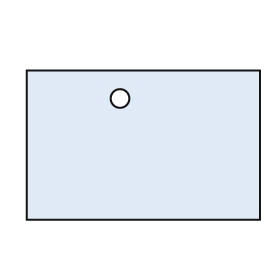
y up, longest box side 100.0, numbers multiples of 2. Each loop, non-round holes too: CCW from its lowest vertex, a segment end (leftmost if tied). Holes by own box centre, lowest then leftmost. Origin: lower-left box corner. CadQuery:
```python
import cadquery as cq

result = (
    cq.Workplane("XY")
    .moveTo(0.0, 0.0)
    .lineTo(100.0, 0.0)
    .lineTo(100.0, 64.0)
    .lineTo(0.0, 64.0)
    .close()
    .moveTo(40.0, 52.0)
    .circle(4.0)
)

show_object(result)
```